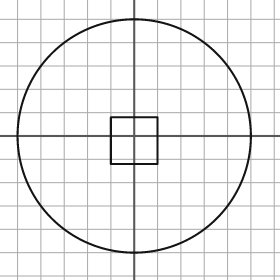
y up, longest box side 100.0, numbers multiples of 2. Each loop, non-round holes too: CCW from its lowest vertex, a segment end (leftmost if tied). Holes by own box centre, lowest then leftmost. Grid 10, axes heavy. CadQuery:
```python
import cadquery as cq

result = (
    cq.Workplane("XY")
    .moveTo(0.0, 0.0)
    .circle(50.0)
    .moveTo(-10.0, -12.0)
    .lineTo(10.0, -12.0)
    .lineTo(10.0, 8.0)
    .lineTo(-10.0, 8.0)
    .close()
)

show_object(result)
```